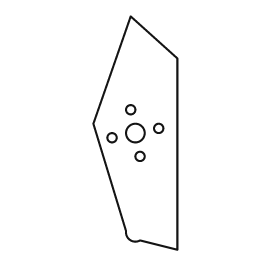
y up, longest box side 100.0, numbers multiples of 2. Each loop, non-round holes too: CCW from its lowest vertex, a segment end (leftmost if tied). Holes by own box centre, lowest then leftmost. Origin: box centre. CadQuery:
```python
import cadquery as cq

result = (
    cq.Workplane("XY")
    .moveTo(18.0, -50.0)
    .lineTo(18.0, 32.0)
    .lineTo(-2.0, 50.0)
    .lineTo(-18.0, 4.0)
    .lineTo(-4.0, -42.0)
    .threePointArc((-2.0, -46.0), (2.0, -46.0))
    .close()
    .moveTo(2.0, -10.0)
    .circle(2.0)
    .moveTo(-10.0, -2.0)
    .circle(2.0)
    .moveTo(0.0, 0.0)
    .circle(4.0)
    .moveTo(10.0, 2.0)
    .circle(2.0)
    .moveTo(-2.0, 10.0)
    .circle(2.0)
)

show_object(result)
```